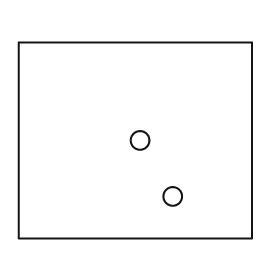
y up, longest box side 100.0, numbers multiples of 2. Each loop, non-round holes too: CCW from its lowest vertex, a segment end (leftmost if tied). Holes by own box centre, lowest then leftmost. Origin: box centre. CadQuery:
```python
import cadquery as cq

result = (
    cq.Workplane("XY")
    .moveTo(-50.0, -42.0)
    .lineTo(50.0, -42.0)
    .lineTo(50.0, 42.0)
    .lineTo(-50.0, 42.0)
    .close()
    .moveTo(16.0, -24.0)
    .circle(4.0)
    .moveTo(2.0, 0.0)
    .circle(4.0)
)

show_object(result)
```